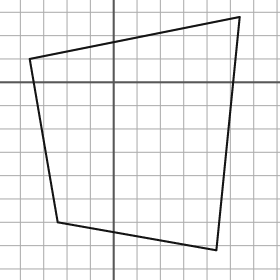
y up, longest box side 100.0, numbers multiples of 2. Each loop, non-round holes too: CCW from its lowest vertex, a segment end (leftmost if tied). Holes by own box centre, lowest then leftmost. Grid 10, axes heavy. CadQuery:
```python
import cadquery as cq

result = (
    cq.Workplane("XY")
    .moveTo(44.0, -72.0)
    .lineTo(54.0, 28.0)
    .lineTo(-36.0, 10.0)
    .lineTo(-24.0, -60.0)
    .close()
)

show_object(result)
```